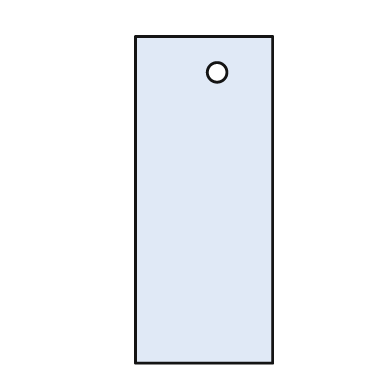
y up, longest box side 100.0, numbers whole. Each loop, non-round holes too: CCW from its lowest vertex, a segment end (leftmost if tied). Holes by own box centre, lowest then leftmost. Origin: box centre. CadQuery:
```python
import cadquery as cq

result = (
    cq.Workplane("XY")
    .moveTo(-21.0, -50.0)
    .lineTo(21.0, -50.0)
    .lineTo(21.0, 50.0)
    .lineTo(-21.0, 50.0)
    .close()
    .moveTo(4.0, 39.0)
    .circle(3.0)
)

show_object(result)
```